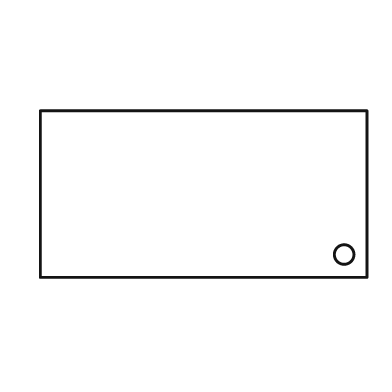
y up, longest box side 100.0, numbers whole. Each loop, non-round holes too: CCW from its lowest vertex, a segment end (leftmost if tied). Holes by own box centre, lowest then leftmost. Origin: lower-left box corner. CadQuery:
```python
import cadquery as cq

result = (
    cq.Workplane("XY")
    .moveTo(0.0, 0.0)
    .lineTo(100.0, 0.0)
    .lineTo(100.0, 51.0)
    .lineTo(0.0, 51.0)
    .close()
    .moveTo(93.0, 7.0)
    .circle(3.0)
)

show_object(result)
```